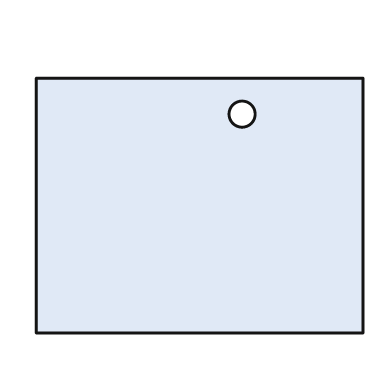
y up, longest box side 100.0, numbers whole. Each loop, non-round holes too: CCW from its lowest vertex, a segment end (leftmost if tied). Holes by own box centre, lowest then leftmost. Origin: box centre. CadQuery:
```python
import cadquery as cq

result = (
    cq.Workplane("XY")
    .moveTo(-50.0, -39.0)
    .lineTo(50.0, -39.0)
    .lineTo(50.0, 39.0)
    .lineTo(-50.0, 39.0)
    .close()
    .moveTo(13.0, 28.0)
    .circle(4.0)
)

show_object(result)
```